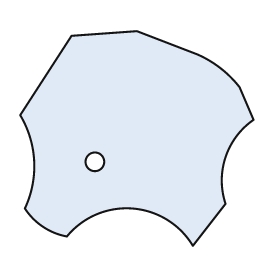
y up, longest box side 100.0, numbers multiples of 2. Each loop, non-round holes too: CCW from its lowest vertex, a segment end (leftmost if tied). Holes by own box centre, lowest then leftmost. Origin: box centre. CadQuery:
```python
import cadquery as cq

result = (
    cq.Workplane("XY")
    .moveTo(24.0, -46.0)
    .lineTo(38.0, -28.0)
    .threePointArc((38.0, -8.0), (50.0, 8.0))
    .lineTo(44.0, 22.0)
    .threePointArc((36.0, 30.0), (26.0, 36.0))
    .lineTo(0.0, 46.0)
    .lineTo(-28.0, 44.0)
    .lineTo(-50.0, 10.0)
    .threePointArc((-44.0, -10.0), (-48.0, -30.0))
    .threePointArc((-40.0, -38.0), (-30.0, -42.0))
    .threePointArc((-2.0, -30.0), (24.0, -46.0))
    .close()
    .moveTo(-18.0, -10.0)
    .circle(4.0)
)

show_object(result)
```